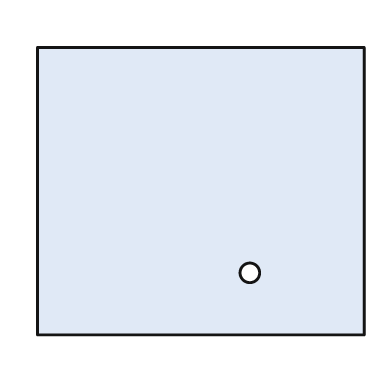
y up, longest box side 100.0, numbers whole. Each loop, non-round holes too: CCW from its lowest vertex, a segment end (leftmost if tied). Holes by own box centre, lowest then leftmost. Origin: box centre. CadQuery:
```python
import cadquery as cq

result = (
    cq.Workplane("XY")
    .moveTo(-50.0, -44.0)
    .lineTo(50.0, -44.0)
    .lineTo(50.0, 44.0)
    .lineTo(-50.0, 44.0)
    .close()
    .moveTo(15.0, -25.0)
    .circle(3.0)
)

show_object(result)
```